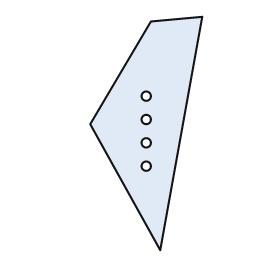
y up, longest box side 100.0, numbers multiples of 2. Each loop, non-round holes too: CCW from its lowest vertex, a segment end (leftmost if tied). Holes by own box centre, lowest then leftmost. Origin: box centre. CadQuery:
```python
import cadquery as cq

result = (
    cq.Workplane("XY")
    .moveTo(6.0, -50.0)
    .lineTo(24.0, 50.0)
    .lineTo(2.0, 48.0)
    .lineTo(-24.0, 4.0)
    .close()
    .moveTo(0.0, -14.0)
    .circle(2.0)
    .moveTo(0.0, -4.0)
    .circle(2.0)
    .moveTo(0.0, 6.0)
    .circle(2.0)
    .moveTo(0.0, 16.0)
    .circle(2.0)
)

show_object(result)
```